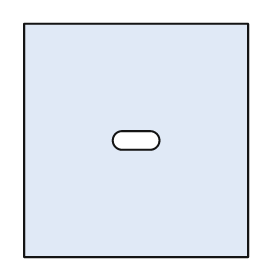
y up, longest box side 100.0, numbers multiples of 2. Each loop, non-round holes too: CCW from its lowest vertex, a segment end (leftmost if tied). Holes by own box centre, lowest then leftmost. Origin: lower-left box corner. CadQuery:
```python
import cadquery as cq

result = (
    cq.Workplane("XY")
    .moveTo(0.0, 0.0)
    .lineTo(96.0, 0.0)
    .lineTo(96.0, 100.0)
    .lineTo(0.0, 100.0)
    .close()
    .moveTo(42.0, 46.0)
    .lineTo(54.0, 46.0)
    .threePointArc((58.0, 50.0), (54.0, 54.0))
    .lineTo(42.0, 54.0)
    .threePointArc((38.0, 50.0), (42.0, 46.0))
    .close()
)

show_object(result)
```